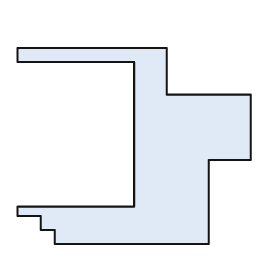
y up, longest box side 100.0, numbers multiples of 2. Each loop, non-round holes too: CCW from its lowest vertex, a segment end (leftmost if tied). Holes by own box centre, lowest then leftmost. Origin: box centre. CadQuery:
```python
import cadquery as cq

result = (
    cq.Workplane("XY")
    .moveTo(-34.0, -42.0)
    .lineTo(32.0, -42.0)
    .lineTo(32.0, -6.0)
    .lineTo(50.0, -6.0)
    .lineTo(50.0, 22.0)
    .lineTo(14.0, 22.0)
    .lineTo(14.0, 42.0)
    .lineTo(-50.0, 42.0)
    .lineTo(-50.0, 36.0)
    .lineTo(0.0, 36.0)
    .lineTo(0.0, -26.0)
    .lineTo(-50.0, -26.0)
    .lineTo(-50.0, -30.0)
    .lineTo(-40.0, -30.0)
    .lineTo(-40.0, -36.0)
    .lineTo(-34.0, -36.0)
    .close()
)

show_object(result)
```